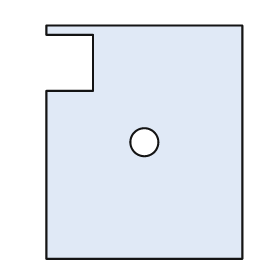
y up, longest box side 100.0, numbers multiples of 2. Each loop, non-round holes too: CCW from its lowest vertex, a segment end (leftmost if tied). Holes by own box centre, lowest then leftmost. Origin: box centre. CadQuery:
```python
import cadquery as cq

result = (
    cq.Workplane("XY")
    .moveTo(-42.0, -50.0)
    .lineTo(42.0, -50.0)
    .lineTo(42.0, 50.0)
    .lineTo(-42.0, 50.0)
    .lineTo(-42.0, 46.0)
    .lineTo(-22.0, 46.0)
    .lineTo(-22.0, 22.0)
    .lineTo(-42.0, 22.0)
    .close()
    .moveTo(0.0, 0.0)
    .circle(6.0)
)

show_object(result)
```